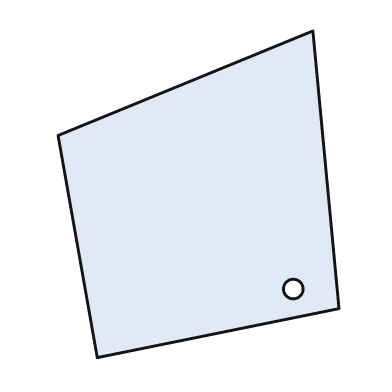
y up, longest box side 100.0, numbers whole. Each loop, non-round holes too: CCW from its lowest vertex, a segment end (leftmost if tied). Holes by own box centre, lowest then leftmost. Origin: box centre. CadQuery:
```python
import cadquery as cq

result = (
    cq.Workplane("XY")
    .moveTo(-31.0, -50.0)
    .lineTo(43.0, -35.0)
    .lineTo(35.0, 50.0)
    .lineTo(-43.0, 18.0)
    .close()
    .moveTo(29.0, -29.0)
    .circle(3.0)
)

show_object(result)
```